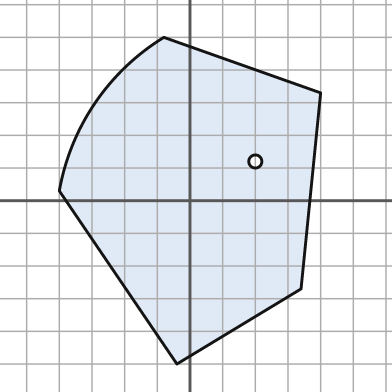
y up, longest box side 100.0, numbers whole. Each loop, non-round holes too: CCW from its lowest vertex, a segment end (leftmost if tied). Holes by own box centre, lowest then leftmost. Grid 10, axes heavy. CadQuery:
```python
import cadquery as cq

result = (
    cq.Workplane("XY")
    .moveTo(-4.0, -50.0)
    .lineTo(34.0, -27.0)
    .lineTo(40.0, 33.0)
    .lineTo(-8.0, 50.0)
    .threePointArc((-29.0, 30.0), (-40.0, 3.0))
    .close()
    .moveTo(20.0, 12.0)
    .circle(2.0)
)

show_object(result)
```